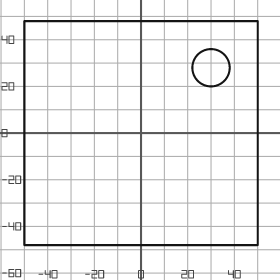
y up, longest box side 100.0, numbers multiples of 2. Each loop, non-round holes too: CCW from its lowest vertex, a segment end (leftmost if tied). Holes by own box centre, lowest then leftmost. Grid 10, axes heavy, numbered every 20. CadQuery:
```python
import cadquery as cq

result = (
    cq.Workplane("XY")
    .moveTo(-50.0, -48.0)
    .lineTo(50.0, -48.0)
    .lineTo(50.0, 48.0)
    .lineTo(-50.0, 48.0)
    .close()
    .moveTo(30.0, 28.0)
    .circle(8.0)
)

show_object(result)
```